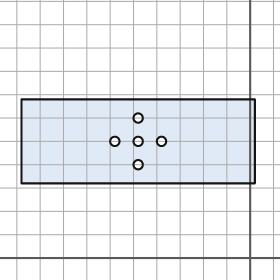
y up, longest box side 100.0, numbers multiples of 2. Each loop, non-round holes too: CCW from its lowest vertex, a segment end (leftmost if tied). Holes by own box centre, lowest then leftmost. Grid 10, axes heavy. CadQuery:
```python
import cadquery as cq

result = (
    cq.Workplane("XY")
    .moveTo(-98.0, 32.0)
    .lineTo(2.0, 32.0)
    .lineTo(2.0, 68.0)
    .lineTo(-98.0, 68.0)
    .close()
    .moveTo(-48.0, 40.0)
    .circle(2.0)
    .moveTo(-58.0, 50.0)
    .circle(2.0)
    .moveTo(-48.0, 50.0)
    .circle(2.0)
    .moveTo(-38.0, 50.0)
    .circle(2.0)
    .moveTo(-48.0, 60.0)
    .circle(2.0)
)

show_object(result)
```